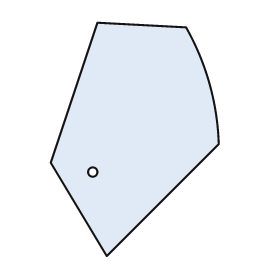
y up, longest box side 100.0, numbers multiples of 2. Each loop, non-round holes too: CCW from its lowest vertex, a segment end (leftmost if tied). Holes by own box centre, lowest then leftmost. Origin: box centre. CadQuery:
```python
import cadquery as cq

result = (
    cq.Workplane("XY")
    .moveTo(-12.0, -50.0)
    .lineTo(36.0, -2.0)
    .threePointArc((32.0, 24.0), (22.0, 48.0))
    .lineTo(-16.0, 50.0)
    .lineTo(-36.0, -10.0)
    .close()
    .moveTo(-18.0, -14.0)
    .circle(2.0)
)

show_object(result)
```